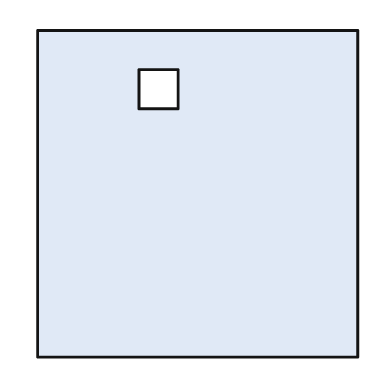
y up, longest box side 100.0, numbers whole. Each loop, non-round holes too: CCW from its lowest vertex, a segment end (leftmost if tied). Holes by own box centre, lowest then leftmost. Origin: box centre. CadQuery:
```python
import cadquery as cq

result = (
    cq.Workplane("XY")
    .moveTo(-49.0, -50.0)
    .lineTo(49.0, -50.0)
    .lineTo(49.0, 50.0)
    .lineTo(-49.0, 50.0)
    .close()
    .moveTo(-18.0, 26.0)
    .lineTo(-6.0, 26.0)
    .lineTo(-6.0, 38.0)
    .lineTo(-18.0, 38.0)
    .close()
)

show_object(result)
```